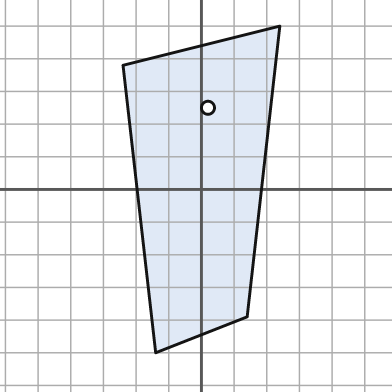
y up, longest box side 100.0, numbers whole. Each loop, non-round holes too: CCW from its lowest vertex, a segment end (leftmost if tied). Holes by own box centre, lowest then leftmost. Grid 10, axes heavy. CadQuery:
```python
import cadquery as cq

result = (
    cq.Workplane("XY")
    .moveTo(-14.0, -50.0)
    .lineTo(14.0, -39.0)
    .lineTo(24.0, 50.0)
    .lineTo(-24.0, 38.0)
    .close()
    .moveTo(2.0, 25.0)
    .circle(2.0)
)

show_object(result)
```